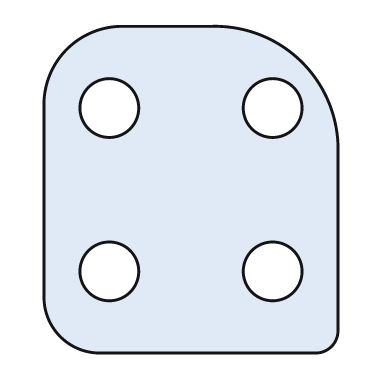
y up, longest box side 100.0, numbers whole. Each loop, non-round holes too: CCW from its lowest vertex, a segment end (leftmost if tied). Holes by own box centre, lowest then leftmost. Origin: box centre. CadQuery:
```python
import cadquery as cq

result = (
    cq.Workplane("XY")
    .moveTo(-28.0, -50.0)
    .lineTo(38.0, -50.0)
    .threePointArc((43.0, -48.0), (45.0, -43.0))
    .lineTo(45.0, 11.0)
    .threePointArc((34.0, 39.0), (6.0, 50.0))
    .lineTo(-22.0, 50.0)
    .threePointArc((-38.0, 43.0), (-45.0, 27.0))
    .lineTo(-45.0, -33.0)
    .threePointArc((-40.0, -45.0), (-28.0, -50.0))
    .close()
    .moveTo(-25.0, -25.0)
    .circle(9.0)
    .moveTo(25.0, -25.0)
    .circle(9.0)
    .moveTo(-25.0, 25.0)
    .circle(9.0)
    .moveTo(25.0, 25.0)
    .circle(9.0)
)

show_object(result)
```